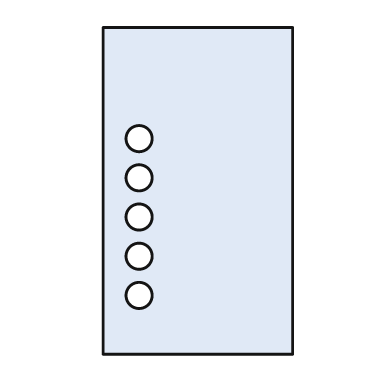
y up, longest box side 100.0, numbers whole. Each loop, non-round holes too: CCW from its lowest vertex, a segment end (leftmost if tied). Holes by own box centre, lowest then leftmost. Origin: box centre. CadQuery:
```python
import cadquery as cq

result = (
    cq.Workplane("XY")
    .moveTo(-29.0, -50.0)
    .lineTo(29.0, -50.0)
    .lineTo(29.0, 50.0)
    .lineTo(-29.0, 50.0)
    .close()
    .moveTo(-18.0, -32.0)
    .circle(4.0)
    .moveTo(-18.0, -20.0)
    .circle(4.0)
    .moveTo(-18.0, -8.0)
    .circle(4.0)
    .moveTo(-18.0, 4.0)
    .circle(4.0)
    .moveTo(-18.0, 16.0)
    .circle(4.0)
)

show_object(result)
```